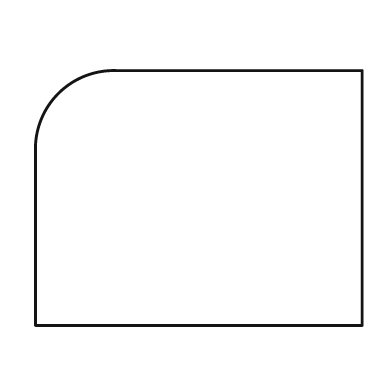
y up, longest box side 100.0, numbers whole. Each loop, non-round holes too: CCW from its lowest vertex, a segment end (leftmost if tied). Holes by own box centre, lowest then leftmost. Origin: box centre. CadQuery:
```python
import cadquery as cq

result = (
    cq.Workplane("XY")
    .moveTo(-50.0, -39.0)
    .lineTo(50.0, -39.0)
    .lineTo(50.0, 39.0)
    .lineTo(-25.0, 39.0)
    .threePointArc((-43.0, 32.0), (-50.0, 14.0))
    .close()
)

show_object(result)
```